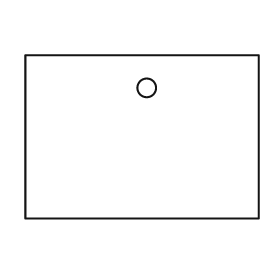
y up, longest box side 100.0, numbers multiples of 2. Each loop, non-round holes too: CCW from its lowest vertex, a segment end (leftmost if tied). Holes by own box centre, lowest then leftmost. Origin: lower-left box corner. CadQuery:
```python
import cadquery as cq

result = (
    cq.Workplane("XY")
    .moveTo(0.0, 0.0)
    .lineTo(100.0, 0.0)
    .lineTo(100.0, 70.0)
    .lineTo(0.0, 70.0)
    .close()
    .moveTo(52.0, 56.0)
    .circle(4.0)
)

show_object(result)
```